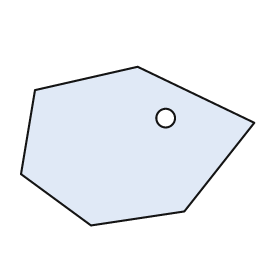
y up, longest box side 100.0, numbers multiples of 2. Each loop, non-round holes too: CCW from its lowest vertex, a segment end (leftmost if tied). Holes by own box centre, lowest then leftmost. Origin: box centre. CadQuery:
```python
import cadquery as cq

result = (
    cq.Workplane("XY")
    .moveTo(-20.0, -34.0)
    .lineTo(20.0, -28.0)
    .lineTo(50.0, 10.0)
    .lineTo(0.0, 34.0)
    .lineTo(-44.0, 24.0)
    .lineTo(-50.0, -12.0)
    .close()
    .moveTo(12.0, 12.0)
    .circle(4.0)
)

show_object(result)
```